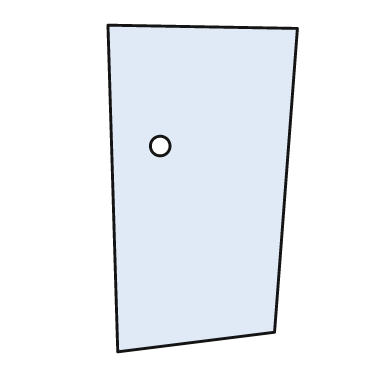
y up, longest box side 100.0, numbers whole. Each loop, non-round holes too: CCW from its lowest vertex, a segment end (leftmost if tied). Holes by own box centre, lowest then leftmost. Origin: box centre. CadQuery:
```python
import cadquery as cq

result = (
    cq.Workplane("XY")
    .moveTo(-26.0, -50.0)
    .lineTo(22.0, -44.0)
    .lineTo(29.0, 49.0)
    .lineTo(-29.0, 50.0)
    .close()
    .moveTo(-13.0, 13.0)
    .circle(3.0)
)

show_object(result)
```